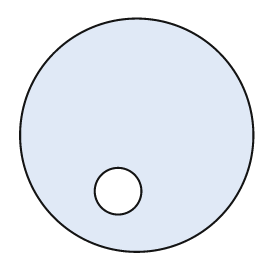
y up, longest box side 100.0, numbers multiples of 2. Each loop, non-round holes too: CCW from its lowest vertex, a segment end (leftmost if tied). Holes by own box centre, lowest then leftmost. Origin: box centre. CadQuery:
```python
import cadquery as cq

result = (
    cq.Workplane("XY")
    .moveTo(0.0, 0.0)
    .circle(50.0)
    .moveTo(-8.0, -24.0)
    .circle(10.0)
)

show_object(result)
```